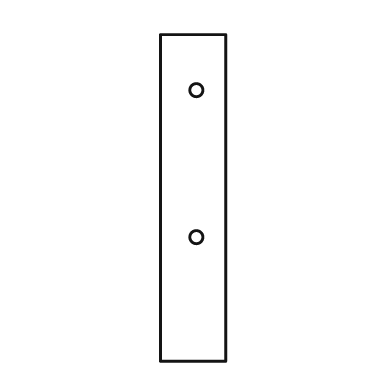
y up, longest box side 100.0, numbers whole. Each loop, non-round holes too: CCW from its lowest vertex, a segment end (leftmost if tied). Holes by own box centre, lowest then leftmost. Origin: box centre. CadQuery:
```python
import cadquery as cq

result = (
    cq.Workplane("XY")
    .moveTo(-10.0, -50.0)
    .lineTo(10.0, -50.0)
    .lineTo(10.0, 50.0)
    .lineTo(-10.0, 50.0)
    .close()
    .moveTo(1.0, -12.0)
    .circle(2.0)
    .moveTo(1.0, 33.0)
    .circle(2.0)
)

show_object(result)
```